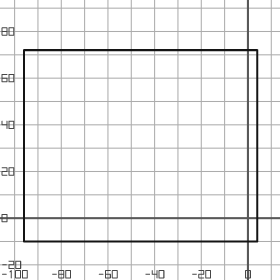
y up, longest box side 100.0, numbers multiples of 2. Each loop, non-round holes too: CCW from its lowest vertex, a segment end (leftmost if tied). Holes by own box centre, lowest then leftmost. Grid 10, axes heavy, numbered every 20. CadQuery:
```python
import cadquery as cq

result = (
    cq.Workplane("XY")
    .moveTo(-96.0, -10.0)
    .lineTo(4.0, -10.0)
    .lineTo(4.0, 72.0)
    .lineTo(-96.0, 72.0)
    .close()
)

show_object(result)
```